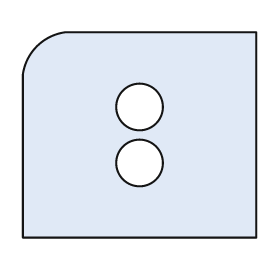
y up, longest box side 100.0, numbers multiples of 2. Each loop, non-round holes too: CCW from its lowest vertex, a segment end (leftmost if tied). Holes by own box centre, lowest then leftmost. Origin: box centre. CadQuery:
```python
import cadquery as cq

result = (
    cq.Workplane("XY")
    .moveTo(-50.0, -44.0)
    .lineTo(50.0, -44.0)
    .lineTo(50.0, 44.0)
    .lineTo(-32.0, 44.0)
    .threePointArc((-44.0, 38.0), (-50.0, 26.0))
    .close()
    .moveTo(0.0, -12.0)
    .circle(10.0)
    .moveTo(0.0, 12.0)
    .circle(10.0)
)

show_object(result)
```